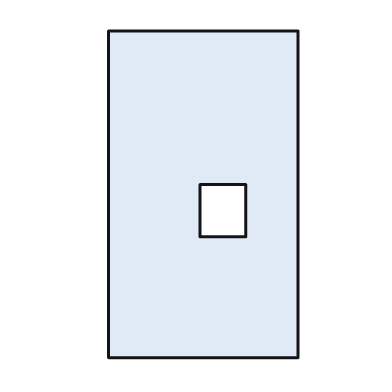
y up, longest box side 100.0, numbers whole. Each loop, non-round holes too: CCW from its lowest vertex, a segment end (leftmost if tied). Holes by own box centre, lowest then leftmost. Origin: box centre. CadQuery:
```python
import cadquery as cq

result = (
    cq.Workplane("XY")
    .moveTo(-29.0, -50.0)
    .lineTo(29.0, -50.0)
    .lineTo(29.0, 50.0)
    .lineTo(-29.0, 50.0)
    .close()
    .moveTo(-1.0, -13.0)
    .lineTo(13.0, -13.0)
    .lineTo(13.0, 3.0)
    .lineTo(-1.0, 3.0)
    .close()
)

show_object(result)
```